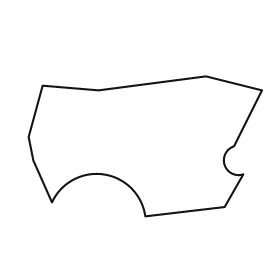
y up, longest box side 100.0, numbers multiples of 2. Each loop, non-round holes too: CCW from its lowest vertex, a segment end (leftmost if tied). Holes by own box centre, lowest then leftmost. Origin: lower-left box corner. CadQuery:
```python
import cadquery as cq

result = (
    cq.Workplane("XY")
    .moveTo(50.0, 0.0)
    .lineTo(84.0, 4.0)
    .lineTo(92.0, 18.0)
    .threePointArc((84.0, 22.0), (88.0, 30.0))
    .lineTo(100.0, 54.0)
    .lineTo(76.0, 60.0)
    .lineTo(30.0, 54.0)
    .lineTo(6.0, 56.0)
    .lineTo(0.0, 34.0)
    .lineTo(2.0, 24.0)
    .lineTo(10.0, 6.0)
    .threePointArc((32.0, 18.0), (50.0, 0.0))
    .close()
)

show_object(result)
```